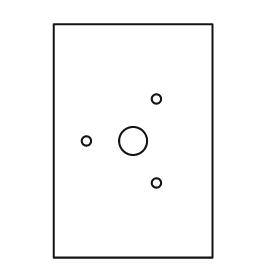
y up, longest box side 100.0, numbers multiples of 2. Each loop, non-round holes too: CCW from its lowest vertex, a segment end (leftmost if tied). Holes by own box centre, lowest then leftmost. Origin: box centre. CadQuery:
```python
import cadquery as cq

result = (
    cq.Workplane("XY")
    .moveTo(-34.0, -50.0)
    .lineTo(34.0, -50.0)
    .lineTo(34.0, 50.0)
    .lineTo(-34.0, 50.0)
    .close()
    .moveTo(10.0, -18.0)
    .circle(2.0)
    .moveTo(-20.0, 0.0)
    .circle(2.0)
    .moveTo(0.0, 0.0)
    .circle(6.0)
    .moveTo(10.0, 18.0)
    .circle(2.0)
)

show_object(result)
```